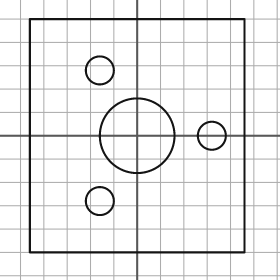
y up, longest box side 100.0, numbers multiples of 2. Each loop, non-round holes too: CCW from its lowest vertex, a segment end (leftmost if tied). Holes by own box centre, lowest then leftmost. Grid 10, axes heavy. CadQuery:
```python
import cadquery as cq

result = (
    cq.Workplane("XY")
    .moveTo(-46.0, -50.0)
    .lineTo(46.0, -50.0)
    .lineTo(46.0, 50.0)
    .lineTo(-46.0, 50.0)
    .close()
    .moveTo(-16.0, -28.0)
    .circle(6.0)
    .moveTo(0.0, 0.0)
    .circle(16.0)
    .moveTo(32.0, 0.0)
    .circle(6.0)
    .moveTo(-16.0, 28.0)
    .circle(6.0)
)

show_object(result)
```